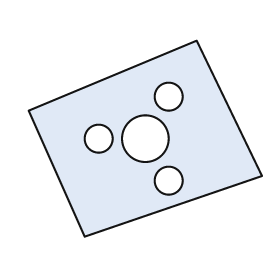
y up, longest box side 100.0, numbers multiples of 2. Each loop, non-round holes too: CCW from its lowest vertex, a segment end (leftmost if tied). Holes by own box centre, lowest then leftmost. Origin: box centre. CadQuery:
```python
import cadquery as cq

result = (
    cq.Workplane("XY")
    .moveTo(-26.0, -42.0)
    .lineTo(50.0, -16.0)
    .lineTo(22.0, 42.0)
    .lineTo(-50.0, 12.0)
    .close()
    .moveTo(10.0, -18.0)
    .circle(6.0)
    .moveTo(-20.0, 0.0)
    .circle(6.0)
    .moveTo(0.0, 0.0)
    .circle(10.0)
    .moveTo(10.0, 18.0)
    .circle(6.0)
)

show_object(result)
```